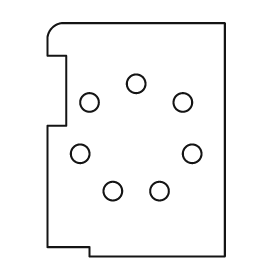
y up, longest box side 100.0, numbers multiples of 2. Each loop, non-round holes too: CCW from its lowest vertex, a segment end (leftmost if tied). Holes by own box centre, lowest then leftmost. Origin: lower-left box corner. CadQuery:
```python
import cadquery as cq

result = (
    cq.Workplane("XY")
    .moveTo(18.0, 0.0)
    .lineTo(76.0, 0.0)
    .lineTo(76.0, 100.0)
    .lineTo(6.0, 100.0)
    .threePointArc((2.0, 98.0), (0.0, 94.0))
    .lineTo(0.0, 86.0)
    .lineTo(8.0, 86.0)
    .lineTo(8.0, 56.0)
    .lineTo(0.0, 56.0)
    .lineTo(0.0, 4.0)
    .lineTo(18.0, 4.0)
    .close()
    .moveTo(28.0, 28.0)
    .circle(4.0)
    .moveTo(48.0, 28.0)
    .circle(4.0)
    .moveTo(14.0, 44.0)
    .circle(4.0)
    .moveTo(62.0, 44.0)
    .circle(4.0)
    .moveTo(18.0, 66.0)
    .circle(4.0)
    .moveTo(58.0, 66.0)
    .circle(4.0)
    .moveTo(38.0, 74.0)
    .circle(4.0)
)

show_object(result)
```